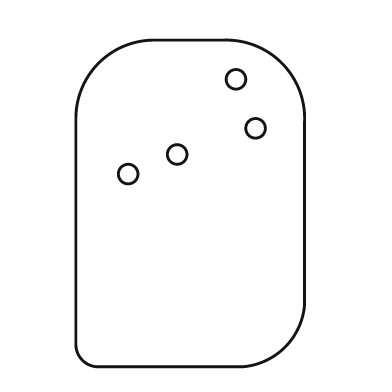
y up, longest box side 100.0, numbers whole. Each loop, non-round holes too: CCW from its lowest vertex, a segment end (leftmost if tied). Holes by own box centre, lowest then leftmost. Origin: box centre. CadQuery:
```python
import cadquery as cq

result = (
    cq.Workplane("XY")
    .moveTo(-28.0, -50.0)
    .lineTo(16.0, -50.0)
    .threePointArc((29.0, -44.0), (35.0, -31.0))
    .lineTo(35.0, 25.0)
    .threePointArc((28.0, 43.0), (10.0, 50.0))
    .lineTo(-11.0, 50.0)
    .threePointArc((-28.0, 43.0), (-35.0, 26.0))
    .lineTo(-35.0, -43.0)
    .threePointArc((-33.0, -48.0), (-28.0, -50.0))
    .close()
    .moveTo(-19.0, 9.0)
    .circle(3.0)
    .moveTo(-4.0, 15.0)
    .circle(3.0)
    .moveTo(20.0, 23.0)
    .circle(3.0)
    .moveTo(14.0, 38.0)
    .circle(3.0)
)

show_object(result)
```